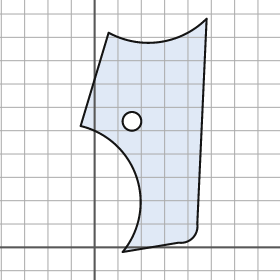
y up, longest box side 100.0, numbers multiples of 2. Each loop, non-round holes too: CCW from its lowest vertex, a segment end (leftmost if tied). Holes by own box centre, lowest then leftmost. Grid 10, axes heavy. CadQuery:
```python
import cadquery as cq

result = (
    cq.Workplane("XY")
    .moveTo(12.0, -2.0)
    .lineTo(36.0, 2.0)
    .threePointArc((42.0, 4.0), (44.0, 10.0))
    .lineTo(48.0, 98.0)
    .threePointArc((28.0, 88.0), (6.0, 92.0))
    .lineTo(-6.0, 52.0)
    .threePointArc((18.0, 30.0), (12.0, -2.0))
    .close()
    .moveTo(16.0, 54.0)
    .circle(4.0)
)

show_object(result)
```